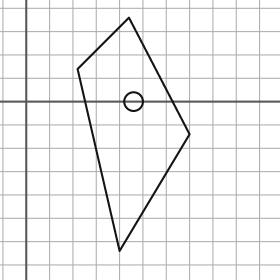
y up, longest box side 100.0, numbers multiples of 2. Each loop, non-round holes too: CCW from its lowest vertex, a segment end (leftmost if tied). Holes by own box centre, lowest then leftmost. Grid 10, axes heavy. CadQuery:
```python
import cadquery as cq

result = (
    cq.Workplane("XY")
    .moveTo(40.0, -64.0)
    .lineTo(70.0, -14.0)
    .lineTo(44.0, 36.0)
    .lineTo(22.0, 14.0)
    .close()
    .moveTo(46.0, 0.0)
    .circle(4.0)
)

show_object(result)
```